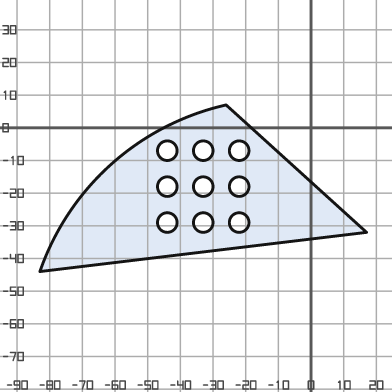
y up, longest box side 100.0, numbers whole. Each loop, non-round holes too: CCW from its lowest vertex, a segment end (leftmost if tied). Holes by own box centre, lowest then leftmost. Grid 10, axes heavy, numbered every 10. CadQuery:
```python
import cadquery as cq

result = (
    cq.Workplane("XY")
    .moveTo(-83.0, -44.0)
    .lineTo(17.0, -32.0)
    .lineTo(-26.0, 7.0)
    .threePointArc((-61.0, -11.0), (-83.0, -44.0))
    .close()
    .moveTo(-44.0, -29.0)
    .circle(3.0)
    .moveTo(-33.0, -29.0)
    .circle(3.0)
    .moveTo(-22.0, -29.0)
    .circle(3.0)
    .moveTo(-44.0, -18.0)
    .circle(3.0)
    .moveTo(-33.0, -18.0)
    .circle(3.0)
    .moveTo(-22.0, -18.0)
    .circle(3.0)
    .moveTo(-44.0, -7.0)
    .circle(3.0)
    .moveTo(-33.0, -7.0)
    .circle(3.0)
    .moveTo(-22.0, -7.0)
    .circle(3.0)
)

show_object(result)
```